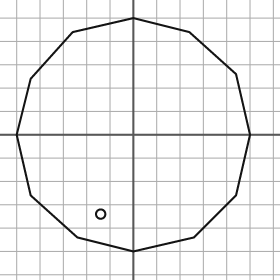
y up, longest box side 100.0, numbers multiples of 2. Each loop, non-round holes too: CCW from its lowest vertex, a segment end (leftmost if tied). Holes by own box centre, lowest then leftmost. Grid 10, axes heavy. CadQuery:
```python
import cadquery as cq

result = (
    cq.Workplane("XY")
    .moveTo(0.0, -50.0)
    .lineTo(26.0, -44.0)
    .lineTo(44.0, -26.0)
    .lineTo(50.0, 0.0)
    .lineTo(44.0, 26.0)
    .lineTo(24.0, 44.0)
    .lineTo(0.0, 50.0)
    .lineTo(-26.0, 44.0)
    .lineTo(-44.0, 24.0)
    .lineTo(-50.0, 0.0)
    .lineTo(-44.0, -26.0)
    .lineTo(-24.0, -44.0)
    .close()
    .moveTo(-14.0, -34.0)
    .circle(2.0)
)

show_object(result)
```